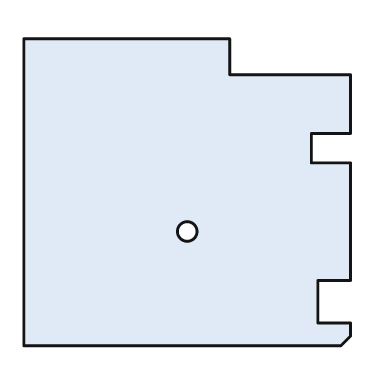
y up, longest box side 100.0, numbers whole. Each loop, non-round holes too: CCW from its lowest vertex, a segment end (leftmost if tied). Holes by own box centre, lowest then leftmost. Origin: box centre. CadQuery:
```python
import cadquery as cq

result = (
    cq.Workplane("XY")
    .moveTo(-50.0, -47.0)
    .lineTo(47.0, -47.0)
    .lineTo(50.0, -44.0)
    .lineTo(50.0, -40.0)
    .lineTo(40.0, -40.0)
    .lineTo(40.0, -27.0)
    .lineTo(50.0, -27.0)
    .lineTo(50.0, 9.0)
    .lineTo(38.0, 9.0)
    .lineTo(38.0, 18.0)
    .lineTo(50.0, 18.0)
    .lineTo(50.0, 36.0)
    .lineTo(13.0, 36.0)
    .lineTo(13.0, 47.0)
    .lineTo(-50.0, 47.0)
    .close()
    .moveTo(0.0, -12.0)
    .circle(3.0)
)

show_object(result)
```